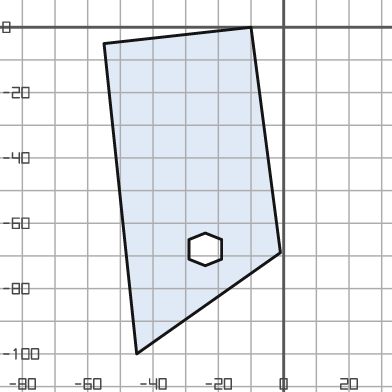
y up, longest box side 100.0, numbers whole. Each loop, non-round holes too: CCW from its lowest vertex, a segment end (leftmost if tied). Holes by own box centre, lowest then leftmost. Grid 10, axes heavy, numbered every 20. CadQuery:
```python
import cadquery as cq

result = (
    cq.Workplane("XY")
    .moveTo(-45.0, -100.0)
    .lineTo(-1.0, -69.0)
    .lineTo(-10.0, 0.0)
    .lineTo(-55.0, -5.0)
    .close()
    .moveTo(-24.0, -73.0)
    .lineTo(-19.0, -71.0)
    .lineTo(-19.0, -65.0)
    .lineTo(-24.0, -63.0)
    .lineTo(-29.0, -65.0)
    .lineTo(-29.0, -71.0)
    .close()
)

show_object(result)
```